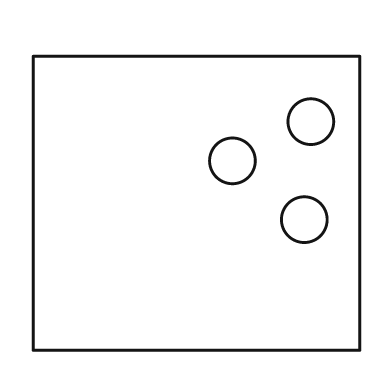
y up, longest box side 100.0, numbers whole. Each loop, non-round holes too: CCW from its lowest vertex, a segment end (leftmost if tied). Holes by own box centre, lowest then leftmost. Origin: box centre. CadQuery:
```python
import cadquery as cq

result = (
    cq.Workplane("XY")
    .moveTo(-50.0, -45.0)
    .lineTo(50.0, -45.0)
    .lineTo(50.0, 45.0)
    .lineTo(-50.0, 45.0)
    .close()
    .moveTo(33.0, -5.0)
    .circle(7.0)
    .moveTo(11.0, 13.0)
    .circle(7.0)
    .moveTo(35.0, 25.0)
    .circle(7.0)
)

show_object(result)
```